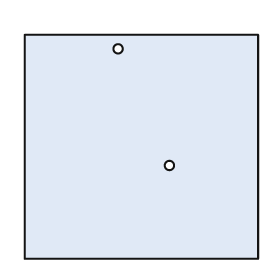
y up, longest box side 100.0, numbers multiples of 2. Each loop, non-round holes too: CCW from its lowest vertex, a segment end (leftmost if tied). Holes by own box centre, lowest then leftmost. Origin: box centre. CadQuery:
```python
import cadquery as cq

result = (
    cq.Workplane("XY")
    .moveTo(-50.0, -48.0)
    .lineTo(50.0, -48.0)
    .lineTo(50.0, 48.0)
    .lineTo(-50.0, 48.0)
    .close()
    .moveTo(12.0, -8.0)
    .circle(2.0)
    .moveTo(-10.0, 42.0)
    .circle(2.0)
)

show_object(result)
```